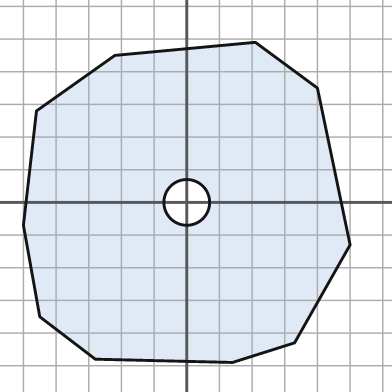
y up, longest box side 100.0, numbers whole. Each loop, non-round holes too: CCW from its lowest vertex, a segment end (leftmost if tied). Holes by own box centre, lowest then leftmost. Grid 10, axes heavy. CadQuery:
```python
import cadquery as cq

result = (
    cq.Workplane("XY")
    .moveTo(14.0, -49.0)
    .lineTo(33.0, -43.0)
    .lineTo(50.0, -13.0)
    .lineTo(40.0, 35.0)
    .lineTo(21.0, 49.0)
    .lineTo(-22.0, 45.0)
    .lineTo(-46.0, 28.0)
    .lineTo(-50.0, -7.0)
    .lineTo(-45.0, -35.0)
    .lineTo(-28.0, -48.0)
    .close()
    .moveTo(0.0, 0.0)
    .circle(7.0)
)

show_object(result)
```